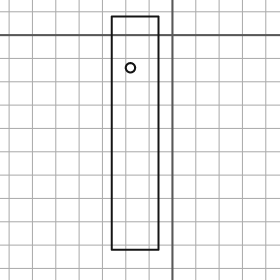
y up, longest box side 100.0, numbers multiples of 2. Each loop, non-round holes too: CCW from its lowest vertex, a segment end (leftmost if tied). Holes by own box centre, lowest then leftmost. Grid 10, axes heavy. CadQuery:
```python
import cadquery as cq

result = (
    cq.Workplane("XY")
    .moveTo(-26.0, -92.0)
    .lineTo(-6.0, -92.0)
    .lineTo(-6.0, 8.0)
    .lineTo(-26.0, 8.0)
    .close()
    .moveTo(-18.0, -14.0)
    .circle(2.0)
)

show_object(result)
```